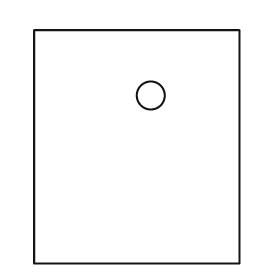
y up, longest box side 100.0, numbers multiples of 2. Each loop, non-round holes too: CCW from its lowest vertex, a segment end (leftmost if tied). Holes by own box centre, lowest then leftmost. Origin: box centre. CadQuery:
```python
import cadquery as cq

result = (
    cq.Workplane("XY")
    .moveTo(-44.0, -50.0)
    .lineTo(44.0, -50.0)
    .lineTo(44.0, 50.0)
    .lineTo(-44.0, 50.0)
    .close()
    .moveTo(6.0, 22.0)
    .circle(6.0)
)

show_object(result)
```